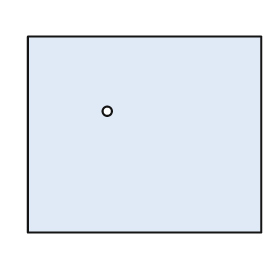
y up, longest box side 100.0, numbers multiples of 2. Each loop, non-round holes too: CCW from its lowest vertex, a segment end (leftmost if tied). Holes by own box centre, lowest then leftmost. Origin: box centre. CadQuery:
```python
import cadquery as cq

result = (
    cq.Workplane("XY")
    .moveTo(-50.0, -42.0)
    .lineTo(50.0, -42.0)
    .lineTo(50.0, 42.0)
    .lineTo(-50.0, 42.0)
    .close()
    .moveTo(-16.0, 10.0)
    .circle(2.0)
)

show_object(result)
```